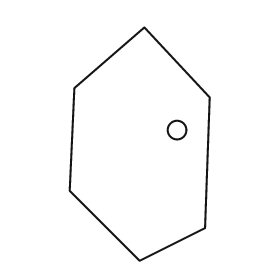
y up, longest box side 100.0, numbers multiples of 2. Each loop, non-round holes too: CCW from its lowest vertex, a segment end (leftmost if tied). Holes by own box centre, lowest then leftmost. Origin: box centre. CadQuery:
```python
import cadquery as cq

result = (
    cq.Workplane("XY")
    .moveTo(0.0, -50.0)
    .lineTo(28.0, -36.0)
    .lineTo(30.0, 20.0)
    .lineTo(2.0, 50.0)
    .lineTo(-28.0, 24.0)
    .lineTo(-30.0, -20.0)
    .close()
    .moveTo(16.0, 6.0)
    .circle(4.0)
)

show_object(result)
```